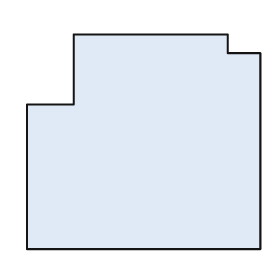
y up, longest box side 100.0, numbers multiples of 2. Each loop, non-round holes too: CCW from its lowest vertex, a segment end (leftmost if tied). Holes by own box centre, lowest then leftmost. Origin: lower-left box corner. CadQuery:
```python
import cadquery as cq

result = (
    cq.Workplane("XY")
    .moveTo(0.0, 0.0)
    .lineTo(100.0, 0.0)
    .lineTo(100.0, 84.0)
    .lineTo(86.0, 84.0)
    .lineTo(86.0, 92.0)
    .lineTo(20.0, 92.0)
    .lineTo(20.0, 62.0)
    .lineTo(0.0, 62.0)
    .close()
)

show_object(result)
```